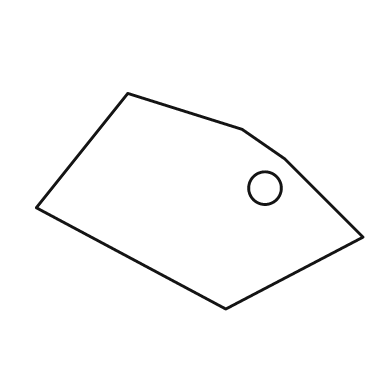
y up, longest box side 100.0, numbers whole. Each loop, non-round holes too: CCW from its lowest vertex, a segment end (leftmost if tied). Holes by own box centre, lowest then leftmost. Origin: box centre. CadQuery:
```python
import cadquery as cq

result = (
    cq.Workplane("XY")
    .moveTo(8.0, -33.0)
    .lineTo(50.0, -11.0)
    .lineTo(26.0, 13.0)
    .lineTo(13.0, 22.0)
    .lineTo(-22.0, 33.0)
    .lineTo(-50.0, -2.0)
    .close()
    .moveTo(20.0, 4.0)
    .circle(5.0)
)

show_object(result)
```